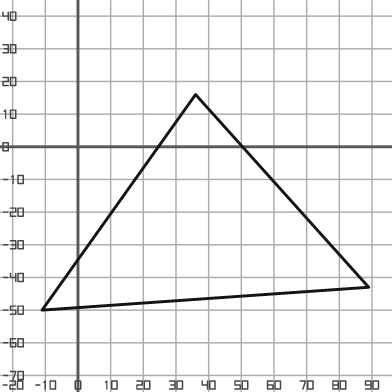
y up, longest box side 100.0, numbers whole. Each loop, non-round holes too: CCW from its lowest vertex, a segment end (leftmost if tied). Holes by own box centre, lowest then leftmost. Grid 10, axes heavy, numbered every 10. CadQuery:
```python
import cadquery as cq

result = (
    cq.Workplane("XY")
    .moveTo(-11.0, -50.0)
    .lineTo(89.0, -43.0)
    .lineTo(36.0, 16.0)
    .close()
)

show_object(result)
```